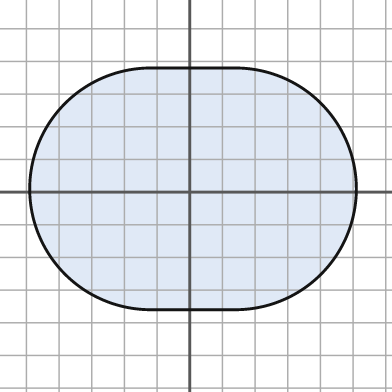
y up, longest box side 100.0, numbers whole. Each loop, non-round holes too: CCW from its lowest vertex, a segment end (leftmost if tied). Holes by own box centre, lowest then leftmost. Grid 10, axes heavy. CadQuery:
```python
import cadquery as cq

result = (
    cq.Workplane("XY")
    .moveTo(-12.0, -36.0)
    .lineTo(14.0, -36.0)
    .threePointArc((51.0, 1.0), (14.0, 38.0))
    .lineTo(-12.0, 38.0)
    .threePointArc((-49.0, 1.0), (-12.0, -36.0))
    .close()
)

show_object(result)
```